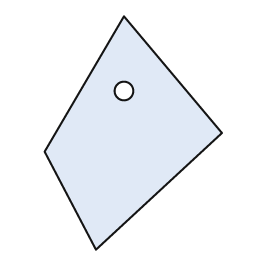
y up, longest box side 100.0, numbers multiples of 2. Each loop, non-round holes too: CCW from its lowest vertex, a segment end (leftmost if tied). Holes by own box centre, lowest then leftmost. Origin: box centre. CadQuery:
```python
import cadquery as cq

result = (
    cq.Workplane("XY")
    .moveTo(-16.0, -50.0)
    .lineTo(38.0, 0.0)
    .lineTo(-4.0, 50.0)
    .lineTo(-38.0, -8.0)
    .close()
    .moveTo(-4.0, 18.0)
    .circle(4.0)
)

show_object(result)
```